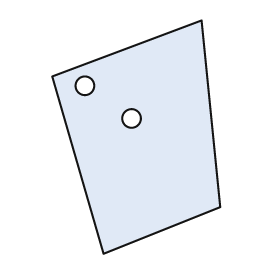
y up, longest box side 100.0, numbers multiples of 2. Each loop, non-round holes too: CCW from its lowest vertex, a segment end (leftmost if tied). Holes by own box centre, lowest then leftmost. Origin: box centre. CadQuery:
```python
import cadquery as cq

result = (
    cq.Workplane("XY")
    .moveTo(-14.0, -50.0)
    .lineTo(36.0, -30.0)
    .lineTo(28.0, 50.0)
    .lineTo(-36.0, 26.0)
    .close()
    .moveTo(-2.0, 8.0)
    .circle(4.0)
    .moveTo(-22.0, 22.0)
    .circle(4.0)
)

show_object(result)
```